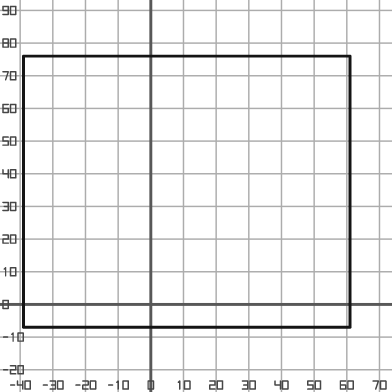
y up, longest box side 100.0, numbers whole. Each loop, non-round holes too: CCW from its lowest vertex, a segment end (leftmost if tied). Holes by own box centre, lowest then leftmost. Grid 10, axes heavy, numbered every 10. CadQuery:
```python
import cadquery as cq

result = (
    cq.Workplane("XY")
    .moveTo(-39.0, -7.0)
    .lineTo(61.0, -7.0)
    .lineTo(61.0, 76.0)
    .lineTo(-39.0, 76.0)
    .close()
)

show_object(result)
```